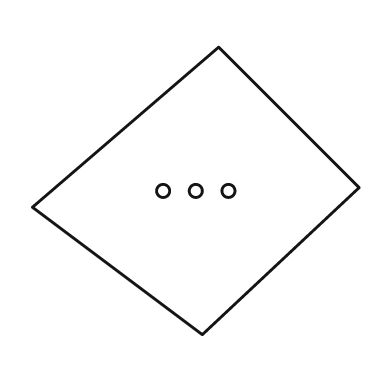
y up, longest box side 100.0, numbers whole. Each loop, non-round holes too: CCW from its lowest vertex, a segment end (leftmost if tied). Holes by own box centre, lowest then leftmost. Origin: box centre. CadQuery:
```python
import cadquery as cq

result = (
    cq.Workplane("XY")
    .moveTo(2.0, -44.0)
    .lineTo(50.0, 1.0)
    .lineTo(7.0, 44.0)
    .lineTo(-50.0, -5.0)
    .close()
    .moveTo(-10.0, 0.0)
    .circle(2.0)
    .moveTo(0.0, 0.0)
    .circle(2.0)
    .moveTo(10.0, 0.0)
    .circle(2.0)
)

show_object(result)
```